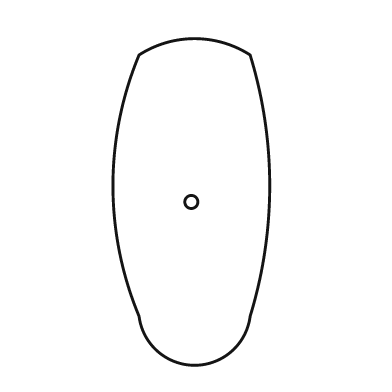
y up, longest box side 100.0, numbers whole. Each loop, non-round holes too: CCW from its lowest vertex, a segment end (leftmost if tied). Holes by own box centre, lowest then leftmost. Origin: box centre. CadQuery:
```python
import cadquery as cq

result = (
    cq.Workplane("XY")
    .moveTo(-16.0, -35.0)
    .threePointArc((1.0, -50.0), (18.0, -35.0))
    .threePointArc((24.0, 5.0), (18.0, 45.0))
    .threePointArc((1.0, 50.0), (-16.0, 45.0))
    .threePointArc((-24.0, 5.0), (-16.0, -35.0))
    .close()
    .moveTo(0.0, 0.0)
    .circle(2.0)
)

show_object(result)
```